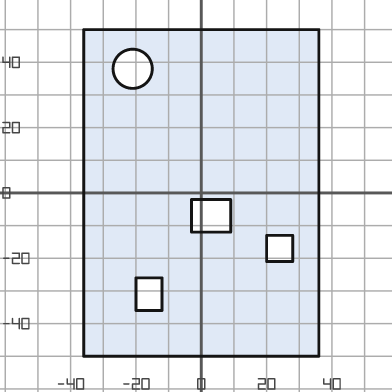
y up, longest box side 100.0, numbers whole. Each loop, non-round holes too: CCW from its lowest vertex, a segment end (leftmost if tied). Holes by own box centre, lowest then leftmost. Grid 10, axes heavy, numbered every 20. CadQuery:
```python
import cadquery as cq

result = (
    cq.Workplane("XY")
    .moveTo(-36.0, -50.0)
    .lineTo(36.0, -50.0)
    .lineTo(36.0, 50.0)
    .lineTo(-36.0, 50.0)
    .close()
    .moveTo(-20.0, -36.0)
    .lineTo(-12.0, -36.0)
    .lineTo(-12.0, -26.0)
    .lineTo(-20.0, -26.0)
    .close()
    .moveTo(20.0, -21.0)
    .lineTo(28.0, -21.0)
    .lineTo(28.0, -13.0)
    .lineTo(20.0, -13.0)
    .close()
    .moveTo(-3.0, -12.0)
    .lineTo(9.0, -12.0)
    .lineTo(9.0, -2.0)
    .lineTo(-3.0, -2.0)
    .close()
    .moveTo(-21.0, 38.0)
    .circle(6.0)
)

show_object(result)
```